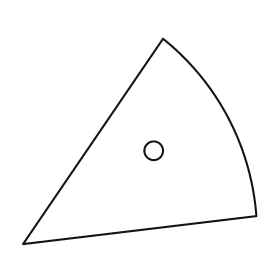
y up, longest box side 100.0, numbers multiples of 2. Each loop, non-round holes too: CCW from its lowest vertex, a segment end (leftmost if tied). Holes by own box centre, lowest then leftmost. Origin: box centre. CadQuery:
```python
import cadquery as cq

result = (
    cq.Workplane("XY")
    .moveTo(-50.0, -44.0)
    .lineTo(50.0, -32.0)
    .threePointArc((38.0, 10.0), (10.0, 44.0))
    .close()
    .moveTo(6.0, -4.0)
    .circle(4.0)
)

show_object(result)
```